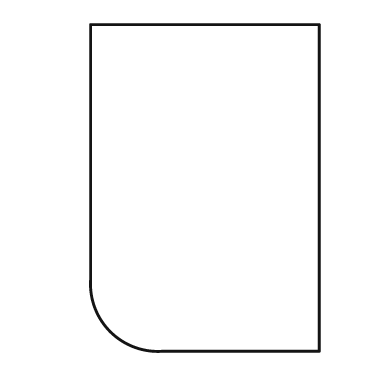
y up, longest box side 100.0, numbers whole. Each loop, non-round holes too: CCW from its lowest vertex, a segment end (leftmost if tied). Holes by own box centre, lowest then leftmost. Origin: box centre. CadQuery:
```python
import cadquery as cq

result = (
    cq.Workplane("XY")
    .moveTo(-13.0, -50.0)
    .lineTo(35.0, -50.0)
    .lineTo(35.0, 50.0)
    .lineTo(-35.0, 50.0)
    .lineTo(-35.0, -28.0)
    .threePointArc((-29.0, -44.0), (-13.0, -50.0))
    .close()
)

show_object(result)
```